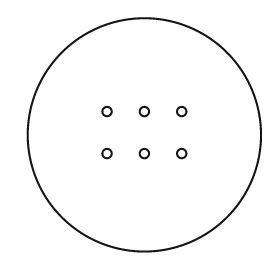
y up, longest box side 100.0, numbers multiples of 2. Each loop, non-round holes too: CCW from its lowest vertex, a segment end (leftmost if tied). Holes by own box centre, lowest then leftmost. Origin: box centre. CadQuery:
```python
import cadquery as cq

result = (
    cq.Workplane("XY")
    .moveTo(0.0, 0.0)
    .circle(50.0)
    .moveTo(-16.0, -8.0)
    .circle(2.0)
    .moveTo(0.0, -8.0)
    .circle(2.0)
    .moveTo(16.0, -8.0)
    .circle(2.0)
    .moveTo(-16.0, 10.0)
    .circle(2.0)
    .moveTo(0.0, 10.0)
    .circle(2.0)
    .moveTo(16.0, 10.0)
    .circle(2.0)
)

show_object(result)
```